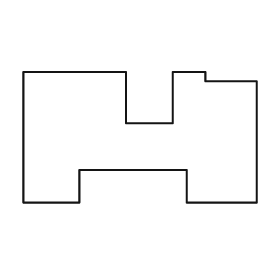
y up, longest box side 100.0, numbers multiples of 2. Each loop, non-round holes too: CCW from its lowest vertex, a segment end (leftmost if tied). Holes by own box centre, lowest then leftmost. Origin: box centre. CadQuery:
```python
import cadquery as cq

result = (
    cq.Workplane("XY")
    .moveTo(-50.0, -28.0)
    .lineTo(-26.0, -28.0)
    .lineTo(-26.0, -14.0)
    .lineTo(20.0, -14.0)
    .lineTo(20.0, -28.0)
    .lineTo(50.0, -28.0)
    .lineTo(50.0, 24.0)
    .lineTo(28.0, 24.0)
    .lineTo(28.0, 28.0)
    .lineTo(14.0, 28.0)
    .lineTo(14.0, 6.0)
    .lineTo(-6.0, 6.0)
    .lineTo(-6.0, 28.0)
    .lineTo(-50.0, 28.0)
    .close()
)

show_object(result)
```